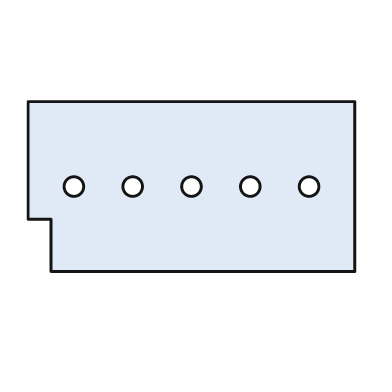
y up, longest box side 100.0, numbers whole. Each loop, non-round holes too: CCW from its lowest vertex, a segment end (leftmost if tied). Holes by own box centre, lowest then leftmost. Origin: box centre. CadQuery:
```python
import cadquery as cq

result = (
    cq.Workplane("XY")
    .moveTo(-43.0, -26.0)
    .lineTo(50.0, -26.0)
    .lineTo(50.0, 26.0)
    .lineTo(-50.0, 26.0)
    .lineTo(-50.0, -10.0)
    .lineTo(-43.0, -10.0)
    .close()
    .moveTo(-36.0, 0.0)
    .circle(3.0)
    .moveTo(-18.0, 0.0)
    .circle(3.0)
    .moveTo(0.0, 0.0)
    .circle(3.0)
    .moveTo(18.0, 0.0)
    .circle(3.0)
    .moveTo(36.0, 0.0)
    .circle(3.0)
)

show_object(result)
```